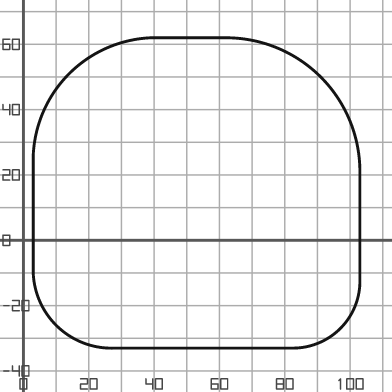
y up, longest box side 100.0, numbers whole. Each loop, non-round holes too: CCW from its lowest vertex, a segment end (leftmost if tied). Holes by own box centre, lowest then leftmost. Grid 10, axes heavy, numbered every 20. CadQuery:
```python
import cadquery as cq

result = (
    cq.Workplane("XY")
    .moveTo(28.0, -33.0)
    .lineTo(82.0, -33.0)
    .threePointArc((97.0, -27.0), (103.0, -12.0))
    .lineTo(103.0, 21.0)
    .threePointArc((91.0, 50.0), (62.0, 62.0))
    .lineTo(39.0, 62.0)
    .threePointArc((14.0, 51.0), (3.0, 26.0))
    .lineTo(3.0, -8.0)
    .threePointArc((10.0, -26.0), (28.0, -33.0))
    .close()
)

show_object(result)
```